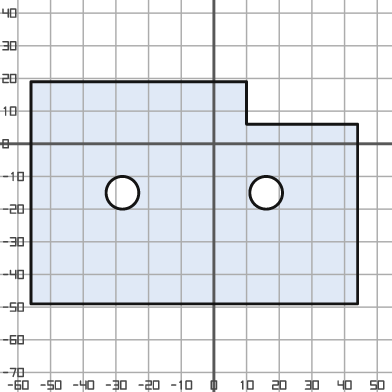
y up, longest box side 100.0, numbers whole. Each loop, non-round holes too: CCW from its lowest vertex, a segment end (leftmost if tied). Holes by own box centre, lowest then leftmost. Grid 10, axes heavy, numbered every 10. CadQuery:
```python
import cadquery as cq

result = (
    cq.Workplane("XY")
    .moveTo(-56.0, -49.0)
    .lineTo(44.0, -49.0)
    .lineTo(44.0, 6.0)
    .lineTo(10.0, 6.0)
    .lineTo(10.0, 19.0)
    .lineTo(-56.0, 19.0)
    .close()
    .moveTo(-28.0, -15.0)
    .circle(5.0)
    .moveTo(16.0, -15.0)
    .circle(5.0)
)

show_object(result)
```